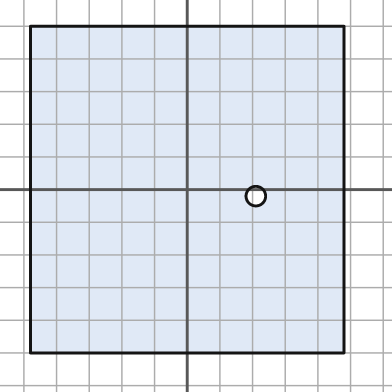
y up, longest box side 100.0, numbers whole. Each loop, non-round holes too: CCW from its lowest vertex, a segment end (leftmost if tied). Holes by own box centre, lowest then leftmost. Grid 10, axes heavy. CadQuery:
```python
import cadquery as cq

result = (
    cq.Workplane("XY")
    .moveTo(-48.0, -50.0)
    .lineTo(48.0, -50.0)
    .lineTo(48.0, 50.0)
    .lineTo(-48.0, 50.0)
    .close()
    .moveTo(21.0, -2.0)
    .circle(3.0)
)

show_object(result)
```